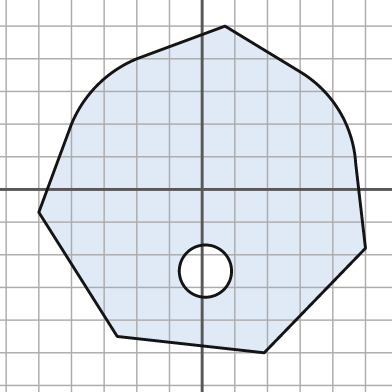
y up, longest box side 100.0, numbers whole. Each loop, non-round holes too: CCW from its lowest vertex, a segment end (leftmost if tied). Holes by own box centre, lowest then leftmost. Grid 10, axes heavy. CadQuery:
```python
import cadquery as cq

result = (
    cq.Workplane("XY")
    .moveTo(19.0, -50.0)
    .lineTo(50.0, -18.0)
    .lineTo(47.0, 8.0)
    .threePointArc((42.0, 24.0), (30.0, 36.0))
    .lineTo(7.0, 50.0)
    .lineTo(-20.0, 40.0)
    .threePointArc((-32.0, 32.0), (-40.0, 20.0))
    .lineTo(-50.0, -7.0)
    .lineTo(-26.0, -45.0)
    .close()
    .moveTo(1.0, -25.0)
    .circle(8.0)
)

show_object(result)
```